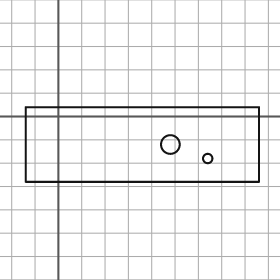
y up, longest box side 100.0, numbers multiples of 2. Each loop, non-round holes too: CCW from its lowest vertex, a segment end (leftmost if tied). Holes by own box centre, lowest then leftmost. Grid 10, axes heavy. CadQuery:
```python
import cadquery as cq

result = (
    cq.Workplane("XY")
    .moveTo(-14.0, -28.0)
    .lineTo(86.0, -28.0)
    .lineTo(86.0, 4.0)
    .lineTo(-14.0, 4.0)
    .close()
    .moveTo(64.0, -18.0)
    .circle(2.0)
    .moveTo(48.0, -12.0)
    .circle(4.0)
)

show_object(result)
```